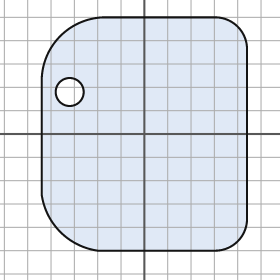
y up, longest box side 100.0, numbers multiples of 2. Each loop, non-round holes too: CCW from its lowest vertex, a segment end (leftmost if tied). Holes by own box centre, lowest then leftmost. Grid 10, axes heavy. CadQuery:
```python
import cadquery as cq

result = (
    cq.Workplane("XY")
    .moveTo(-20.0, -50.0)
    .lineTo(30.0, -50.0)
    .threePointArc((40.0, -46.0), (44.0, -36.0))
    .lineTo(44.0, 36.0)
    .threePointArc((40.0, 46.0), (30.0, 50.0))
    .lineTo(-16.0, 50.0)
    .threePointArc((-36.0, 42.0), (-44.0, 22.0))
    .lineTo(-44.0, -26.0)
    .threePointArc((-36.0, -42.0), (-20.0, -50.0))
    .close()
    .moveTo(-32.0, 18.0)
    .circle(6.0)
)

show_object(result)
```